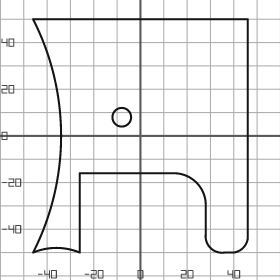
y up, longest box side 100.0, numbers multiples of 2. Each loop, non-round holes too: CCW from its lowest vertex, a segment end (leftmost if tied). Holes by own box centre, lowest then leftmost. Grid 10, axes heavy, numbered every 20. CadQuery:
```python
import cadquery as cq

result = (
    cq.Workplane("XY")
    .moveTo(-46.0, -50.0)
    .threePointArc((-36.0, -48.0), (-26.0, -50.0))
    .lineTo(-26.0, -16.0)
    .lineTo(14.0, -16.0)
    .threePointArc((24.0, -20.0), (28.0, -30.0))
    .lineTo(28.0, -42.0)
    .threePointArc((30.0, -48.0), (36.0, -50.0))
    .lineTo(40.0, -50.0)
    .threePointArc((44.0, -48.0), (46.0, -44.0))
    .lineTo(46.0, 50.0)
    .lineTo(-46.0, 50.0)
    .threePointArc((-34.0, 0.0), (-46.0, -50.0))
    .close()
    .moveTo(-8.0, 8.0)
    .circle(4.0)
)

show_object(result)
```